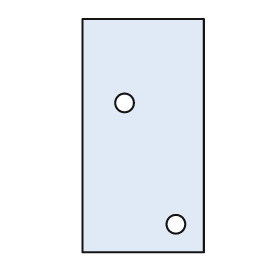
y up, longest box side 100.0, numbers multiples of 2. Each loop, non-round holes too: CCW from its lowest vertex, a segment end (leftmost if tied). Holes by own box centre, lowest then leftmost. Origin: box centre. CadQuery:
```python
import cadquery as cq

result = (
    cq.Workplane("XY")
    .moveTo(-26.0, -50.0)
    .lineTo(26.0, -50.0)
    .lineTo(26.0, 50.0)
    .lineTo(-26.0, 50.0)
    .close()
    .moveTo(14.0, -38.0)
    .circle(4.0)
    .moveTo(-8.0, 14.0)
    .circle(4.0)
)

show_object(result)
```